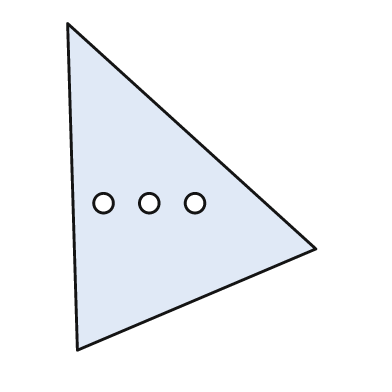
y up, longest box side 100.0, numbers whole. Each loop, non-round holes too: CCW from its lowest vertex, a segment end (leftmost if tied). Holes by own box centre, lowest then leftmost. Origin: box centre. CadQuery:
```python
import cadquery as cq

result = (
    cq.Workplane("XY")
    .moveTo(-35.0, -50.0)
    .lineTo(38.0, -19.0)
    .lineTo(-38.0, 50.0)
    .close()
    .moveTo(-27.0, -5.0)
    .circle(3.0)
    .moveTo(-13.0, -5.0)
    .circle(3.0)
    .moveTo(1.0, -5.0)
    .circle(3.0)
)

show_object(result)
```